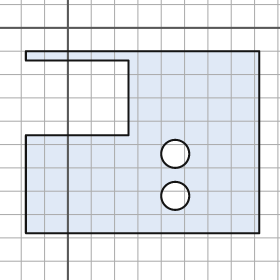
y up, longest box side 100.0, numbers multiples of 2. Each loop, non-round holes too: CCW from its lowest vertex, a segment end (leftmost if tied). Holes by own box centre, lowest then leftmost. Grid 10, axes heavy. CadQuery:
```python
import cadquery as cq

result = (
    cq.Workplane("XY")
    .moveTo(-18.0, -88.0)
    .lineTo(82.0, -88.0)
    .lineTo(82.0, -10.0)
    .lineTo(-18.0, -10.0)
    .lineTo(-18.0, -14.0)
    .lineTo(26.0, -14.0)
    .lineTo(26.0, -46.0)
    .lineTo(-18.0, -46.0)
    .close()
    .moveTo(46.0, -72.0)
    .circle(6.0)
    .moveTo(46.0, -54.0)
    .circle(6.0)
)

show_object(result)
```